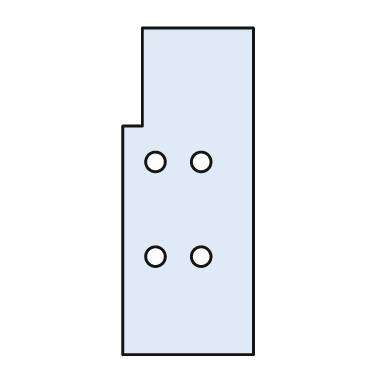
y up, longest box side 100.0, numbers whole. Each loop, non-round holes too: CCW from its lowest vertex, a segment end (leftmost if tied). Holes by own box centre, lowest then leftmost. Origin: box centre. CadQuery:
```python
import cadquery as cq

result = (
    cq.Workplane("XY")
    .moveTo(-20.0, -50.0)
    .lineTo(20.0, -50.0)
    .lineTo(20.0, 50.0)
    .lineTo(-14.0, 50.0)
    .lineTo(-14.0, 20.0)
    .lineTo(-20.0, 20.0)
    .close()
    .moveTo(-10.0, -20.0)
    .circle(3.0)
    .moveTo(4.0, -20.0)
    .circle(3.0)
    .moveTo(-10.0, 9.0)
    .circle(3.0)
    .moveTo(4.0, 9.0)
    .circle(3.0)
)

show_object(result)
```